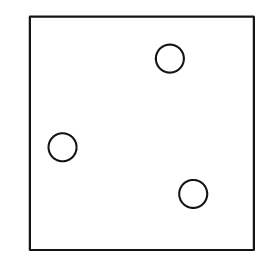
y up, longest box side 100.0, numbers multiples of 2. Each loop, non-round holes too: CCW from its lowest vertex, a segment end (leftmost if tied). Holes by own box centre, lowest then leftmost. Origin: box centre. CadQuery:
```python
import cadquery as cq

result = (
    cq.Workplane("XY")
    .moveTo(-48.0, -50.0)
    .lineTo(48.0, -50.0)
    .lineTo(48.0, 50.0)
    .lineTo(-48.0, 50.0)
    .close()
    .moveTo(22.0, -26.0)
    .circle(6.0)
    .moveTo(-34.0, -6.0)
    .circle(6.0)
    .moveTo(12.0, 32.0)
    .circle(6.0)
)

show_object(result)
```